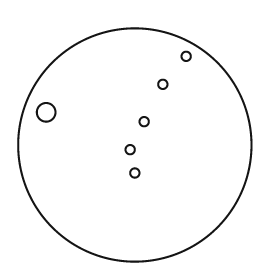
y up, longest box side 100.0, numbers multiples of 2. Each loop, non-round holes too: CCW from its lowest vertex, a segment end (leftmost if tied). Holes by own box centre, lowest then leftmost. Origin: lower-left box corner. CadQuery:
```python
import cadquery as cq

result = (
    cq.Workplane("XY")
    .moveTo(50.0, 50.0)
    .circle(50.0)
    .moveTo(50.0, 38.0)
    .circle(2.0)
    .moveTo(48.0, 48.0)
    .circle(2.0)
    .moveTo(54.0, 60.0)
    .circle(2.0)
    .moveTo(12.0, 64.0)
    .circle(4.0)
    .moveTo(62.0, 76.0)
    .circle(2.0)
    .moveTo(72.0, 88.0)
    .circle(2.0)
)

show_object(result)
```